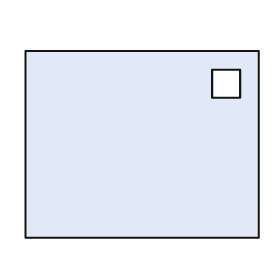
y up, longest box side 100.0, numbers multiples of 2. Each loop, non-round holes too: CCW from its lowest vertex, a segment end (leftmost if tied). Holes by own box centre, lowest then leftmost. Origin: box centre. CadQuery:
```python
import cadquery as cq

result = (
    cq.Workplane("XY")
    .moveTo(-50.0, -40.0)
    .lineTo(50.0, -40.0)
    .lineTo(50.0, 40.0)
    .lineTo(-50.0, 40.0)
    .close()
    .moveTo(30.0, 20.0)
    .lineTo(42.0, 20.0)
    .lineTo(42.0, 32.0)
    .lineTo(30.0, 32.0)
    .close()
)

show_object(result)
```